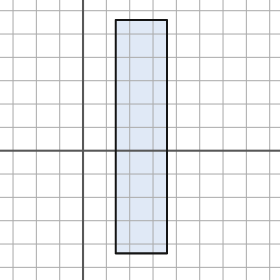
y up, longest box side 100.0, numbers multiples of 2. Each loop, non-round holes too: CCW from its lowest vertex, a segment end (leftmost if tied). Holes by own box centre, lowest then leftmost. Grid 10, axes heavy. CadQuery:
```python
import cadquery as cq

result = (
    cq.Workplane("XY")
    .moveTo(14.0, -44.0)
    .lineTo(36.0, -44.0)
    .lineTo(36.0, 56.0)
    .lineTo(14.0, 56.0)
    .close()
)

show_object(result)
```